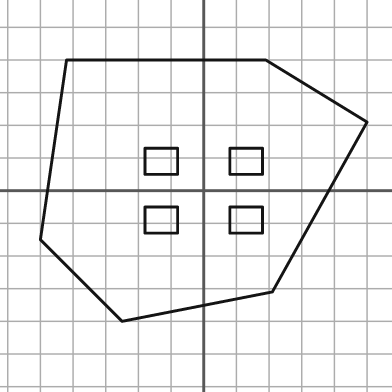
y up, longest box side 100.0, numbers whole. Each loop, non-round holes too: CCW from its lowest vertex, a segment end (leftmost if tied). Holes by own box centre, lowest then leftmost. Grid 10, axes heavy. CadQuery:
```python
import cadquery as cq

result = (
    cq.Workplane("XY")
    .moveTo(-25.0, -40.0)
    .lineTo(21.0, -31.0)
    .lineTo(50.0, 21.0)
    .lineTo(19.0, 40.0)
    .lineTo(-42.0, 40.0)
    .lineTo(-50.0, -15.0)
    .close()
    .moveTo(-18.0, -13.0)
    .lineTo(-8.0, -13.0)
    .lineTo(-8.0, -5.0)
    .lineTo(-18.0, -5.0)
    .close()
    .moveTo(8.0, -13.0)
    .lineTo(18.0, -13.0)
    .lineTo(18.0, -5.0)
    .lineTo(8.0, -5.0)
    .close()
    .moveTo(-18.0, 5.0)
    .lineTo(-8.0, 5.0)
    .lineTo(-8.0, 13.0)
    .lineTo(-18.0, 13.0)
    .close()
    .moveTo(8.0, 5.0)
    .lineTo(18.0, 5.0)
    .lineTo(18.0, 13.0)
    .lineTo(8.0, 13.0)
    .close()
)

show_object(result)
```